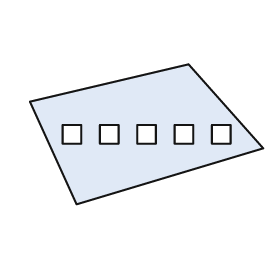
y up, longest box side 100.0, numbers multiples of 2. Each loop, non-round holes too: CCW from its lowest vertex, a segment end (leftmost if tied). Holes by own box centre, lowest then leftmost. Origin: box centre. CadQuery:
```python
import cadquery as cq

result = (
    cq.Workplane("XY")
    .moveTo(-30.0, -30.0)
    .lineTo(50.0, -6.0)
    .lineTo(18.0, 30.0)
    .lineTo(-50.0, 14.0)
    .close()
    .moveTo(-36.0, -4.0)
    .lineTo(-28.0, -4.0)
    .lineTo(-28.0, 4.0)
    .lineTo(-36.0, 4.0)
    .close()
    .moveTo(-20.0, -4.0)
    .lineTo(-12.0, -4.0)
    .lineTo(-12.0, 4.0)
    .lineTo(-20.0, 4.0)
    .close()
    .moveTo(-4.0, -4.0)
    .lineTo(4.0, -4.0)
    .lineTo(4.0, 4.0)
    .lineTo(-4.0, 4.0)
    .close()
    .moveTo(12.0, -4.0)
    .lineTo(20.0, -4.0)
    .lineTo(20.0, 4.0)
    .lineTo(12.0, 4.0)
    .close()
    .moveTo(28.0, -4.0)
    .lineTo(36.0, -4.0)
    .lineTo(36.0, 4.0)
    .lineTo(28.0, 4.0)
    .close()
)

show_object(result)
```